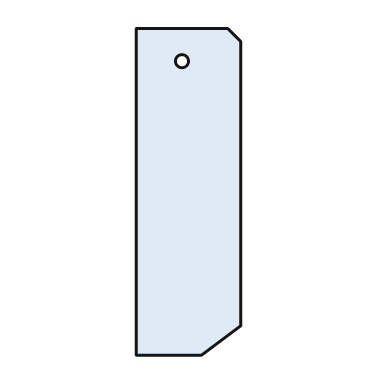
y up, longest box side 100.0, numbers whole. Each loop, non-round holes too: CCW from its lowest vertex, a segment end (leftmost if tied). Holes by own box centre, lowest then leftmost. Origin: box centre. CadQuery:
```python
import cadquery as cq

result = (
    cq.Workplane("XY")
    .moveTo(-16.0, -50.0)
    .lineTo(4.0, -50.0)
    .lineTo(16.0, -41.0)
    .lineTo(16.0, 46.0)
    .lineTo(12.0, 50.0)
    .lineTo(-16.0, 50.0)
    .close()
    .moveTo(-2.0, 40.0)
    .circle(2.0)
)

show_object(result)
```